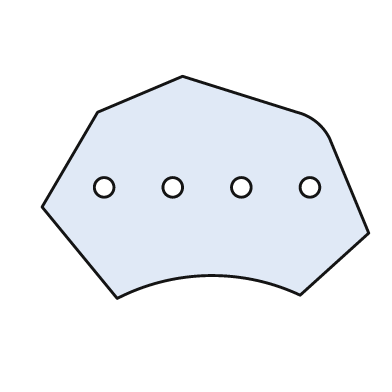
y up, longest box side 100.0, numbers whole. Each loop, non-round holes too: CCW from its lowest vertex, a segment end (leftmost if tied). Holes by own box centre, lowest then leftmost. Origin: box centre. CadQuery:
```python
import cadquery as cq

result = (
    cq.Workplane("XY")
    .moveTo(-27.0, -34.0)
    .threePointArc((1.0, -27.0), (29.0, -33.0))
    .lineTo(50.0, -14.0)
    .lineTo(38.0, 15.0)
    .threePointArc((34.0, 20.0), (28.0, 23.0))
    .lineTo(-7.0, 34.0)
    .lineTo(-33.0, 23.0)
    .lineTo(-50.0, -6.0)
    .close()
    .moveTo(-31.0, 0.0)
    .circle(3.0)
    .moveTo(-10.0, 0.0)
    .circle(3.0)
    .moveTo(11.0, 0.0)
    .circle(3.0)
    .moveTo(32.0, 0.0)
    .circle(3.0)
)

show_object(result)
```